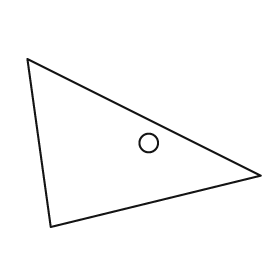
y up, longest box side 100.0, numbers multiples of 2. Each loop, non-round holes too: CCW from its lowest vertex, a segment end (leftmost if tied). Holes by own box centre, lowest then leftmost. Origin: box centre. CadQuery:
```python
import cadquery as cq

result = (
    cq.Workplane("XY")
    .moveTo(-40.0, -36.0)
    .lineTo(50.0, -14.0)
    .lineTo(-50.0, 36.0)
    .close()
    .moveTo(2.0, 0.0)
    .circle(4.0)
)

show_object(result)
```